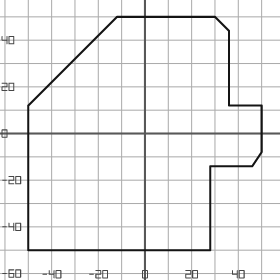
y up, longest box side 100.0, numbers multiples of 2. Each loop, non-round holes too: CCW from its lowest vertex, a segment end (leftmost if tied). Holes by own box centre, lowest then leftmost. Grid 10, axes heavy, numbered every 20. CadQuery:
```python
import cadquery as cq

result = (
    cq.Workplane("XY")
    .moveTo(-50.0, -50.0)
    .lineTo(28.0, -50.0)
    .lineTo(28.0, -14.0)
    .lineTo(46.0, -14.0)
    .lineTo(50.0, -8.0)
    .lineTo(50.0, 12.0)
    .lineTo(36.0, 12.0)
    .lineTo(36.0, 44.0)
    .lineTo(30.0, 50.0)
    .lineTo(-12.0, 50.0)
    .lineTo(-50.0, 12.0)
    .close()
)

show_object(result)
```